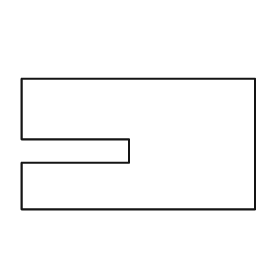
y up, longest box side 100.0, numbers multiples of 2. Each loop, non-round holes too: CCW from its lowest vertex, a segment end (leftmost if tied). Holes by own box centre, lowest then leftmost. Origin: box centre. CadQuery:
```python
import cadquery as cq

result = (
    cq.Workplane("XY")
    .moveTo(-50.0, -28.0)
    .lineTo(50.0, -28.0)
    .lineTo(50.0, 28.0)
    .lineTo(-50.0, 28.0)
    .lineTo(-50.0, 2.0)
    .lineTo(-4.0, 2.0)
    .lineTo(-4.0, -8.0)
    .lineTo(-50.0, -8.0)
    .close()
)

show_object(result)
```